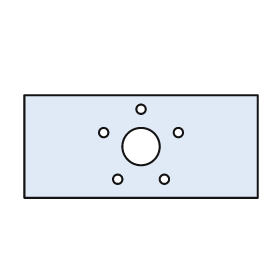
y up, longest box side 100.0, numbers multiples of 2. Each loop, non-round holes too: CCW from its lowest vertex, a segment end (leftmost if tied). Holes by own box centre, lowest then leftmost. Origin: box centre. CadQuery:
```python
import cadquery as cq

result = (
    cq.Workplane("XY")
    .moveTo(-50.0, -22.0)
    .lineTo(50.0, -22.0)
    .lineTo(50.0, 22.0)
    .lineTo(-50.0, 22.0)
    .close()
    .moveTo(-10.0, -14.0)
    .circle(2.0)
    .moveTo(10.0, -14.0)
    .circle(2.0)
    .moveTo(0.0, 0.0)
    .circle(8.0)
    .moveTo(-16.0, 6.0)
    .circle(2.0)
    .moveTo(16.0, 6.0)
    .circle(2.0)
    .moveTo(0.0, 16.0)
    .circle(2.0)
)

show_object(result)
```